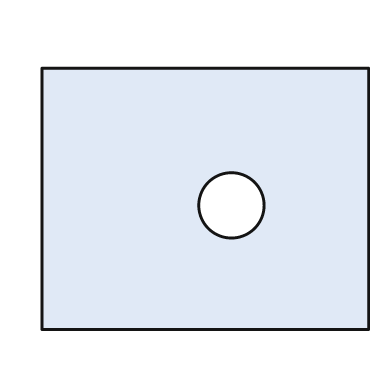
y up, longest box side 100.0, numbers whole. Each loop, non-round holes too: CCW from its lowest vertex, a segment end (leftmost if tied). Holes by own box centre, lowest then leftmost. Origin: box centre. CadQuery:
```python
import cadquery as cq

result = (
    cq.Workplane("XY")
    .moveTo(-50.0, -40.0)
    .lineTo(50.0, -40.0)
    .lineTo(50.0, 40.0)
    .lineTo(-50.0, 40.0)
    .close()
    .moveTo(8.0, -2.0)
    .circle(10.0)
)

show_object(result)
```